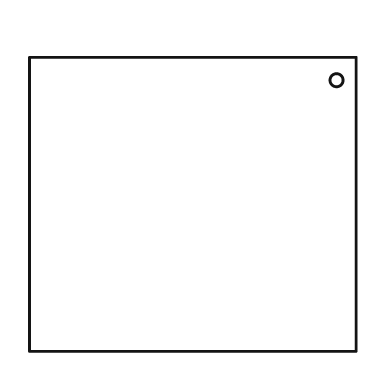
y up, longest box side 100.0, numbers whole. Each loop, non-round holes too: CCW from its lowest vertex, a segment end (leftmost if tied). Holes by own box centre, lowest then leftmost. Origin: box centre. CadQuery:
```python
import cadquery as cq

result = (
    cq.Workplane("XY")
    .moveTo(-50.0, -45.0)
    .lineTo(50.0, -45.0)
    .lineTo(50.0, 45.0)
    .lineTo(-50.0, 45.0)
    .close()
    .moveTo(44.0, 38.0)
    .circle(2.0)
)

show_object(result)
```